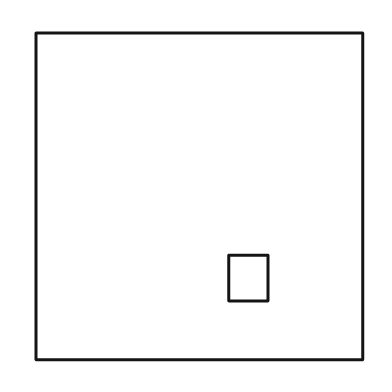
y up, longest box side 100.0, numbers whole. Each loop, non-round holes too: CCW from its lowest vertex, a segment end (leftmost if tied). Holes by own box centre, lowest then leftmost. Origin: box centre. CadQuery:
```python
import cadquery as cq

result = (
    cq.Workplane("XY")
    .moveTo(-50.0, -50.0)
    .lineTo(50.0, -50.0)
    .lineTo(50.0, 50.0)
    .lineTo(-50.0, 50.0)
    .close()
    .moveTo(9.0, -32.0)
    .lineTo(21.0, -32.0)
    .lineTo(21.0, -18.0)
    .lineTo(9.0, -18.0)
    .close()
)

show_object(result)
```